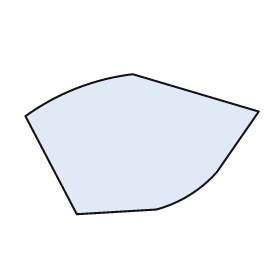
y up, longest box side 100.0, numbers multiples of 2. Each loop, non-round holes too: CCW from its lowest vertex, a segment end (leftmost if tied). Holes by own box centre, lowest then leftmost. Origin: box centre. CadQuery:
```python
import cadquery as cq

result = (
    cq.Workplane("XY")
    .moveTo(-28.0, -30.0)
    .lineTo(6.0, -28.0)
    .threePointArc((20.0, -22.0), (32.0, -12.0))
    .lineTo(50.0, 14.0)
    .lineTo(-4.0, 30.0)
    .threePointArc((-28.0, 24.0), (-50.0, 12.0))
    .close()
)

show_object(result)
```